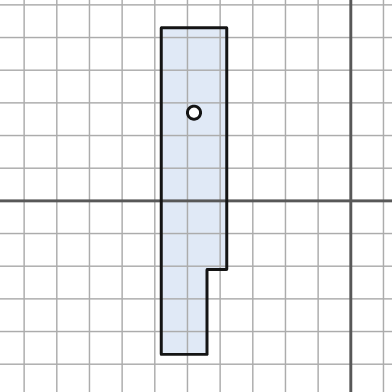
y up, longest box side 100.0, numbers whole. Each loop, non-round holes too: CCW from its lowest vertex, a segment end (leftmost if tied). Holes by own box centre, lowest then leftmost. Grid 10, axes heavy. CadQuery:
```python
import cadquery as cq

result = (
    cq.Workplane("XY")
    .moveTo(-58.0, -47.0)
    .lineTo(-44.0, -47.0)
    .lineTo(-44.0, -21.0)
    .lineTo(-38.0, -21.0)
    .lineTo(-38.0, 53.0)
    .lineTo(-58.0, 53.0)
    .close()
    .moveTo(-48.0, 27.0)
    .circle(2.0)
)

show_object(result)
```